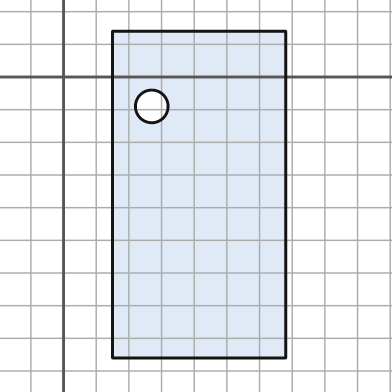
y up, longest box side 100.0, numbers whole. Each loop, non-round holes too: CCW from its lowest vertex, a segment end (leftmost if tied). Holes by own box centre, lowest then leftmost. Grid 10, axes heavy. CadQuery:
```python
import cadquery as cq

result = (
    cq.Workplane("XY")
    .moveTo(15.0, -86.0)
    .lineTo(68.0, -86.0)
    .lineTo(68.0, 14.0)
    .lineTo(15.0, 14.0)
    .close()
    .moveTo(27.0, -9.0)
    .circle(5.0)
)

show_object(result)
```